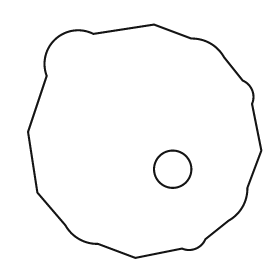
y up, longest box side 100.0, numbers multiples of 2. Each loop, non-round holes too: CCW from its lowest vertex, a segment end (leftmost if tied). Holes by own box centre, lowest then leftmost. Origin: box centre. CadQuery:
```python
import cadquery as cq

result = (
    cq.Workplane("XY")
    .moveTo(-4.0, -50.0)
    .lineTo(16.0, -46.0)
    .threePointArc((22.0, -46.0), (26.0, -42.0))
    .lineTo(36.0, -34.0)
    .threePointArc((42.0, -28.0), (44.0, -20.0))
    .lineTo(50.0, -4.0)
    .lineTo(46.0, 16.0)
    .threePointArc((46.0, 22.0), (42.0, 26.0))
    .lineTo(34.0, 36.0)
    .threePointArc((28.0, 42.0), (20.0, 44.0))
    .lineTo(4.0, 50.0)
    .lineTo(-22.0, 46.0)
    .threePointArc((-38.0, 44.0), (-42.0, 28.0))
    .lineTo(-50.0, 4.0)
    .lineTo(-46.0, -22.0)
    .lineTo(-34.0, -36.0)
    .threePointArc((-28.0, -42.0), (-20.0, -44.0))
    .close()
    .moveTo(12.0, -12.0)
    .circle(8.0)
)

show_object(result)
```